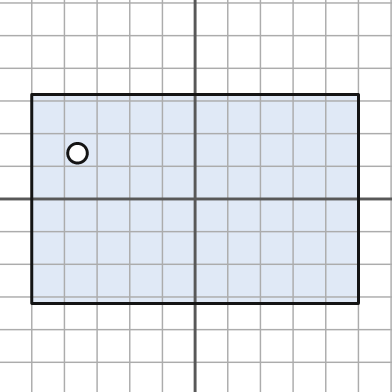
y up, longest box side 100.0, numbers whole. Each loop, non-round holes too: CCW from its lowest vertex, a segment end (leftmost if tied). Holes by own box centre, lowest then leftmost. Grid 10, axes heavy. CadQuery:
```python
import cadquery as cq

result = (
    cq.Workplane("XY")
    .moveTo(-50.0, -32.0)
    .lineTo(50.0, -32.0)
    .lineTo(50.0, 32.0)
    .lineTo(-50.0, 32.0)
    .close()
    .moveTo(-36.0, 14.0)
    .circle(3.0)
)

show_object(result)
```